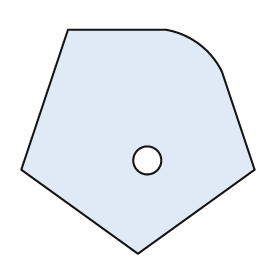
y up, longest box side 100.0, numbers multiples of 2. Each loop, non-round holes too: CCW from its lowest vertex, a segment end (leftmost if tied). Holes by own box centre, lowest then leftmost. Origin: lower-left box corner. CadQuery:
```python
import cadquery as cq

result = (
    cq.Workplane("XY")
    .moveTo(50.0, 0.0)
    .lineTo(100.0, 36.0)
    .lineTo(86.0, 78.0)
    .threePointArc((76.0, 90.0), (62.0, 96.0))
    .lineTo(20.0, 96.0)
    .lineTo(0.0, 36.0)
    .close()
    .moveTo(54.0, 40.0)
    .circle(6.0)
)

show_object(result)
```